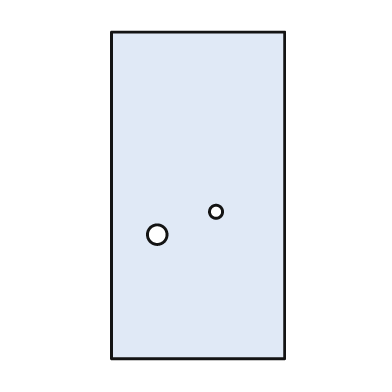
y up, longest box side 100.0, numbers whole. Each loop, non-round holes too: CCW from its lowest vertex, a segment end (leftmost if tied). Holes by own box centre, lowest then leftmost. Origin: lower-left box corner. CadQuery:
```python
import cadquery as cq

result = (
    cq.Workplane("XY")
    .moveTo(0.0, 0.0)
    .lineTo(53.0, 0.0)
    .lineTo(53.0, 100.0)
    .lineTo(0.0, 100.0)
    .close()
    .moveTo(14.0, 38.0)
    .circle(3.0)
    .moveTo(32.0, 45.0)
    .circle(2.0)
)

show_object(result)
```